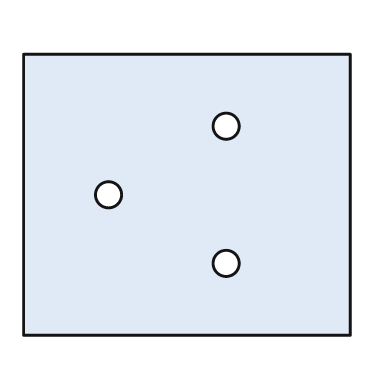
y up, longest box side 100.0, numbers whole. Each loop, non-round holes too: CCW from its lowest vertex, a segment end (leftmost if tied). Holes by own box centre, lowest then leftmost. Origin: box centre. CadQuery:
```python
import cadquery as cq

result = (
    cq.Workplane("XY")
    .moveTo(-50.0, -43.0)
    .lineTo(50.0, -43.0)
    .lineTo(50.0, 43.0)
    .lineTo(-50.0, 43.0)
    .close()
    .moveTo(12.0, -21.0)
    .circle(4.0)
    .moveTo(-24.0, 0.0)
    .circle(4.0)
    .moveTo(12.0, 21.0)
    .circle(4.0)
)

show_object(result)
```